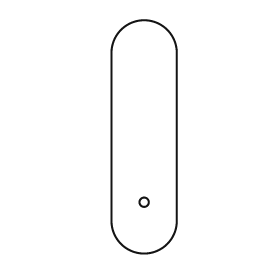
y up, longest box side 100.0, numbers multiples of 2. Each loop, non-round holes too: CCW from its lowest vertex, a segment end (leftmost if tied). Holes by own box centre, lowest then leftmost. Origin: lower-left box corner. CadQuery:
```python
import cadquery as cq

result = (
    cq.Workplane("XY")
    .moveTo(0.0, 14.0)
    .threePointArc((14.0, 0.0), (28.0, 14.0))
    .lineTo(28.0, 86.0)
    .threePointArc((14.0, 100.0), (0.0, 86.0))
    .close()
    .moveTo(14.0, 22.0)
    .circle(2.0)
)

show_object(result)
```